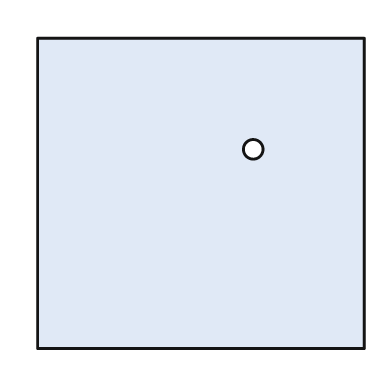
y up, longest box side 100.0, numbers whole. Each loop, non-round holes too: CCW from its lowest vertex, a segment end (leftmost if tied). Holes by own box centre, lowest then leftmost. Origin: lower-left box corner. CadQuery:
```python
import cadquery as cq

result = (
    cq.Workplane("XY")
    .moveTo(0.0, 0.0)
    .lineTo(100.0, 0.0)
    .lineTo(100.0, 95.0)
    .lineTo(0.0, 95.0)
    .close()
    .moveTo(66.0, 61.0)
    .circle(3.0)
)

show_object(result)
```